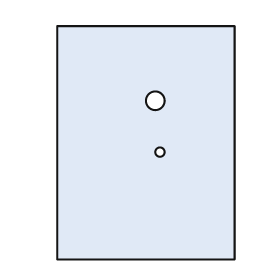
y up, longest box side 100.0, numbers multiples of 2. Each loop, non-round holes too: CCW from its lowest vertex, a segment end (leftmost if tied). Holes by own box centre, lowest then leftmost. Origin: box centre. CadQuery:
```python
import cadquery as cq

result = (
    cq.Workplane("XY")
    .moveTo(-38.0, -50.0)
    .lineTo(38.0, -50.0)
    .lineTo(38.0, 50.0)
    .lineTo(-38.0, 50.0)
    .close()
    .moveTo(6.0, -4.0)
    .circle(2.0)
    .moveTo(4.0, 18.0)
    .circle(4.0)
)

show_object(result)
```